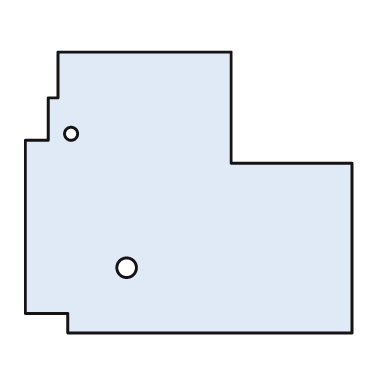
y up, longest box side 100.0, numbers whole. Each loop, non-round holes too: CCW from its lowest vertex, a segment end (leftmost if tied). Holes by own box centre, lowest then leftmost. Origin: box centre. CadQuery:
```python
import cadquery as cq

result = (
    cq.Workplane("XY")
    .moveTo(-37.0, -43.0)
    .lineTo(50.0, -43.0)
    .lineTo(50.0, 9.0)
    .lineTo(13.0, 9.0)
    .lineTo(13.0, 43.0)
    .lineTo(-40.0, 43.0)
    .lineTo(-40.0, 29.0)
    .lineTo(-43.0, 29.0)
    .lineTo(-43.0, 16.0)
    .lineTo(-50.0, 16.0)
    .lineTo(-50.0, -37.0)
    .lineTo(-37.0, -37.0)
    .close()
    .moveTo(-19.0, -23.0)
    .circle(3.0)
    .moveTo(-36.0, 18.0)
    .circle(2.0)
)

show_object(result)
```